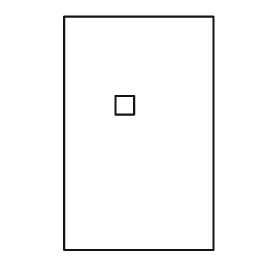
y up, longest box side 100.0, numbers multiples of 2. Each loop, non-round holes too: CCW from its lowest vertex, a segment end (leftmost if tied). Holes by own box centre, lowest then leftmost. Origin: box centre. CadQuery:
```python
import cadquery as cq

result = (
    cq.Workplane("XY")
    .moveTo(-32.0, -50.0)
    .lineTo(32.0, -50.0)
    .lineTo(32.0, 50.0)
    .lineTo(-32.0, 50.0)
    .close()
    .moveTo(-10.0, 8.0)
    .lineTo(-2.0, 8.0)
    .lineTo(-2.0, 16.0)
    .lineTo(-10.0, 16.0)
    .close()
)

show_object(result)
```